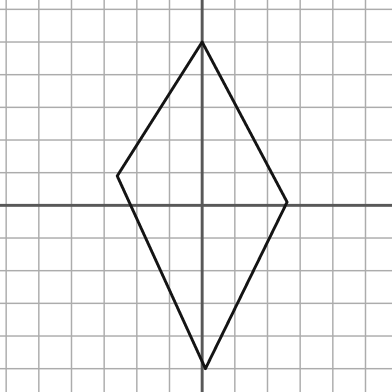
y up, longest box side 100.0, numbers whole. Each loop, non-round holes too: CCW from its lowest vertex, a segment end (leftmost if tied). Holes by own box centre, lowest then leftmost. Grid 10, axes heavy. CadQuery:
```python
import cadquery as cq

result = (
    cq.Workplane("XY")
    .moveTo(1.0, -50.0)
    .lineTo(26.0, 1.0)
    .lineTo(0.0, 50.0)
    .lineTo(-26.0, 9.0)
    .close()
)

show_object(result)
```